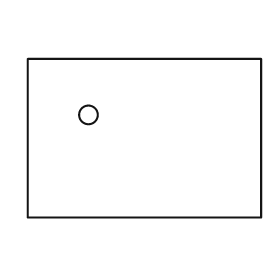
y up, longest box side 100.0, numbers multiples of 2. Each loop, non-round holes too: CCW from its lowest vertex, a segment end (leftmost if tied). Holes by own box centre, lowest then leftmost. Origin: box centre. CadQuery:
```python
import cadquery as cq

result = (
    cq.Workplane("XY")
    .moveTo(-50.0, -34.0)
    .lineTo(50.0, -34.0)
    .lineTo(50.0, 34.0)
    .lineTo(-50.0, 34.0)
    .close()
    .moveTo(-24.0, 10.0)
    .circle(4.0)
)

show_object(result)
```